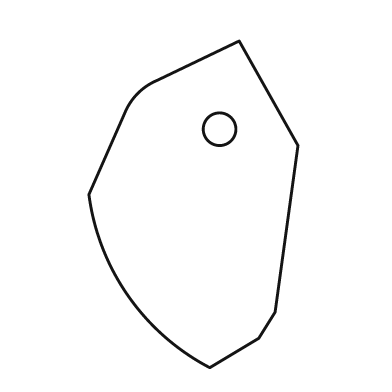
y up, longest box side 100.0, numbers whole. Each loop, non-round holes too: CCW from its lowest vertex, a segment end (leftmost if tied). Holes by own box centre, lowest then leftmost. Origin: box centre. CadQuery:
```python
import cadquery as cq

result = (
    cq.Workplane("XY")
    .moveTo(5.0, -50.0)
    .lineTo(20.0, -41.0)
    .lineTo(25.0, -33.0)
    .lineTo(32.0, 18.0)
    .lineTo(14.0, 50.0)
    .lineTo(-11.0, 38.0)
    .threePointArc((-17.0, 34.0), (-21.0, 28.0))
    .lineTo(-32.0, 3.0)
    .threePointArc((-20.0, -28.0), (5.0, -50.0))
    .close()
    .moveTo(8.0, 23.0)
    .circle(5.0)
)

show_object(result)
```